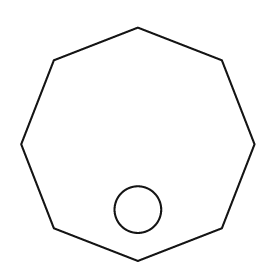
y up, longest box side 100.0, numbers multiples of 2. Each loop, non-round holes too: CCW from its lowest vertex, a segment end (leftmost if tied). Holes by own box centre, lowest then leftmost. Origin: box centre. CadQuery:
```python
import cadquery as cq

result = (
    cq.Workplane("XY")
    .moveTo(0.0, -50.0)
    .lineTo(36.0, -36.0)
    .lineTo(50.0, 0.0)
    .lineTo(36.0, 36.0)
    .lineTo(0.0, 50.0)
    .lineTo(-36.0, 36.0)
    .lineTo(-50.0, 0.0)
    .lineTo(-36.0, -36.0)
    .close()
    .moveTo(0.0, -28.0)
    .circle(10.0)
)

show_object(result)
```